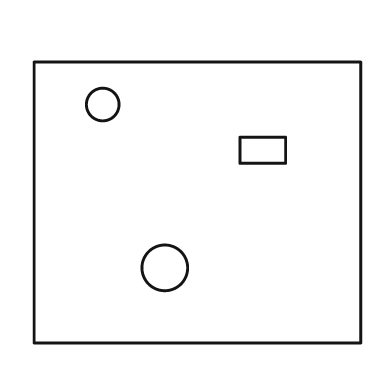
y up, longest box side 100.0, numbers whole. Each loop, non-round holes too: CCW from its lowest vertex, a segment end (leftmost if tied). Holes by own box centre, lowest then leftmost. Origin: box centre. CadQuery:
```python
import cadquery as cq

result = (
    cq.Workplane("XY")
    .moveTo(-50.0, -43.0)
    .lineTo(50.0, -43.0)
    .lineTo(50.0, 43.0)
    .lineTo(-50.0, 43.0)
    .close()
    .moveTo(-10.0, -20.0)
    .circle(7.0)
    .moveTo(13.0, 12.0)
    .lineTo(27.0, 12.0)
    .lineTo(27.0, 20.0)
    .lineTo(13.0, 20.0)
    .close()
    .moveTo(-29.0, 30.0)
    .circle(5.0)
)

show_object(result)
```